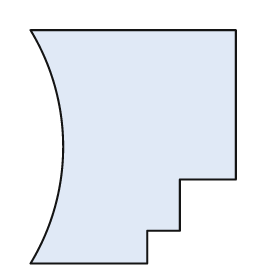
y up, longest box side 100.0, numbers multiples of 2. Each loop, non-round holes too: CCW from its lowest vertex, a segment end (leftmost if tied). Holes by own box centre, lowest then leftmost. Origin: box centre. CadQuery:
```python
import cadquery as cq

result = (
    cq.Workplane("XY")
    .moveTo(-44.0, -50.0)
    .lineTo(6.0, -50.0)
    .lineTo(6.0, -36.0)
    .lineTo(20.0, -36.0)
    .lineTo(20.0, -14.0)
    .lineTo(44.0, -14.0)
    .lineTo(44.0, 50.0)
    .lineTo(-44.0, 50.0)
    .threePointArc((-30.0, 0.0), (-44.0, -50.0))
    .close()
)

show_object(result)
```